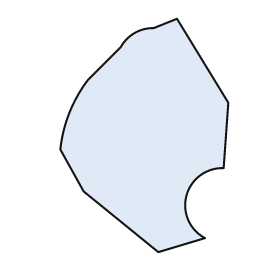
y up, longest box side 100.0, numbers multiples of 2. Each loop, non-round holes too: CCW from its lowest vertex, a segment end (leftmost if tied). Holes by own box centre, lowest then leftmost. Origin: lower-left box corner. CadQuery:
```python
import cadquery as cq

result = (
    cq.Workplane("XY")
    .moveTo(42.0, 0.0)
    .lineTo(62.0, 6.0)
    .threePointArc((54.0, 24.0), (70.0, 36.0))
    .lineTo(72.0, 64.0)
    .lineTo(50.0, 100.0)
    .lineTo(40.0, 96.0)
    .threePointArc((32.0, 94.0), (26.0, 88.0))
    .lineTo(12.0, 74.0)
    .threePointArc((4.0, 60.0), (0.0, 44.0))
    .lineTo(10.0, 26.0)
    .close()
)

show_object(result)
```